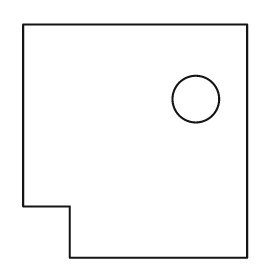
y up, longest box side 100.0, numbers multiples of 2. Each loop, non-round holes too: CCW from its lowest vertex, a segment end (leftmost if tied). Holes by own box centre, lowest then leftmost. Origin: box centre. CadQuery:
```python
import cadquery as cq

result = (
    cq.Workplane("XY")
    .moveTo(-28.0, -50.0)
    .lineTo(48.0, -50.0)
    .lineTo(48.0, 50.0)
    .lineTo(-48.0, 50.0)
    .lineTo(-48.0, -28.0)
    .lineTo(-28.0, -28.0)
    .close()
    .moveTo(26.0, 18.0)
    .circle(10.0)
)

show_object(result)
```